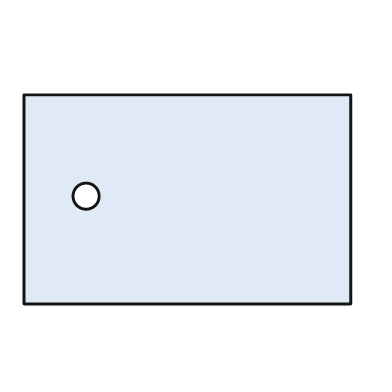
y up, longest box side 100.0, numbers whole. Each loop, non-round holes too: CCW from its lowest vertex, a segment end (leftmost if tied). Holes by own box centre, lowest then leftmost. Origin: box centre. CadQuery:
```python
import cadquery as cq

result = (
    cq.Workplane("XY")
    .moveTo(-50.0, -32.0)
    .lineTo(50.0, -32.0)
    .lineTo(50.0, 32.0)
    .lineTo(-50.0, 32.0)
    .close()
    .moveTo(-31.0, 1.0)
    .circle(4.0)
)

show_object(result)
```